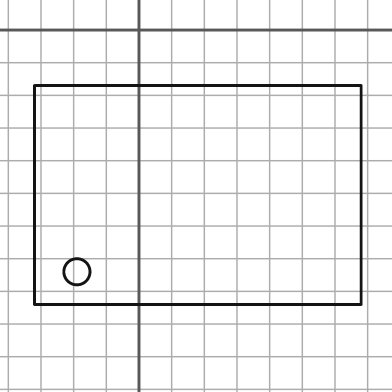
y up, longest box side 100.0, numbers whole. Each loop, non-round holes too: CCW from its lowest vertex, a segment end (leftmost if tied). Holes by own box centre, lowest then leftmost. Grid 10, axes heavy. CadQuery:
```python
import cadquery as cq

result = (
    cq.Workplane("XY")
    .moveTo(-32.0, -84.0)
    .lineTo(68.0, -84.0)
    .lineTo(68.0, -17.0)
    .lineTo(-32.0, -17.0)
    .close()
    .moveTo(-19.0, -74.0)
    .circle(4.0)
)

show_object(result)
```